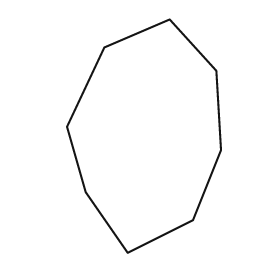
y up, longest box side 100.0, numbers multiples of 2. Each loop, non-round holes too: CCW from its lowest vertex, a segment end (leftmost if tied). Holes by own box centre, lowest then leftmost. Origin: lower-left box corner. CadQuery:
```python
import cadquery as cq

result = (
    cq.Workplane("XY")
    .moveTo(26.0, 0.0)
    .lineTo(54.0, 14.0)
    .lineTo(66.0, 44.0)
    .lineTo(64.0, 78.0)
    .lineTo(44.0, 100.0)
    .lineTo(16.0, 88.0)
    .lineTo(0.0, 54.0)
    .lineTo(8.0, 26.0)
    .close()
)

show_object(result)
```